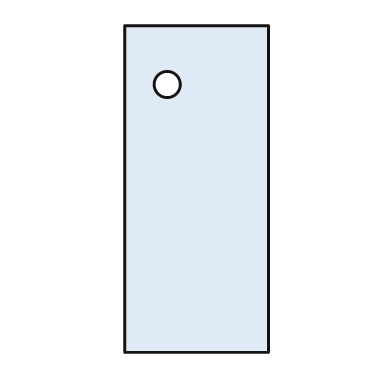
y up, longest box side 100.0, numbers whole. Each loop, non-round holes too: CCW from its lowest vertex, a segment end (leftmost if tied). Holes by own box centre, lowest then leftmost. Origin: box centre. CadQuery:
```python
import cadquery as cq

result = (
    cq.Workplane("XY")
    .moveTo(-22.0, -50.0)
    .lineTo(22.0, -50.0)
    .lineTo(22.0, 50.0)
    .lineTo(-22.0, 50.0)
    .close()
    .moveTo(-9.0, 32.0)
    .circle(4.0)
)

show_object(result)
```